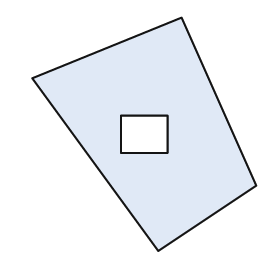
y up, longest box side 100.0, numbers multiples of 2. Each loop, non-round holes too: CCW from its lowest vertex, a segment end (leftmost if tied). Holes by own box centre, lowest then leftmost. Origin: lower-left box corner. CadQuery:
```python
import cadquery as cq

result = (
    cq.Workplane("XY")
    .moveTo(54.0, 0.0)
    .lineTo(96.0, 28.0)
    .lineTo(64.0, 100.0)
    .lineTo(0.0, 74.0)
    .close()
    .moveTo(38.0, 42.0)
    .lineTo(58.0, 42.0)
    .lineTo(58.0, 58.0)
    .lineTo(38.0, 58.0)
    .close()
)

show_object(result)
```